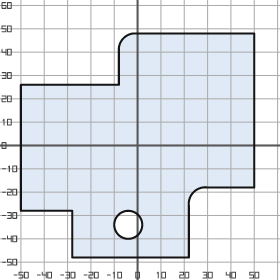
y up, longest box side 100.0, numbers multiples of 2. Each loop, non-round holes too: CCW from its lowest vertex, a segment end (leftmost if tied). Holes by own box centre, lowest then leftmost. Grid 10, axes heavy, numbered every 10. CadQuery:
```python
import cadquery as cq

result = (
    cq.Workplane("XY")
    .moveTo(-28.0, -48.0)
    .lineTo(22.0, -48.0)
    .lineTo(22.0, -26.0)
    .threePointArc((24.0, -20.0), (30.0, -18.0))
    .lineTo(50.0, -18.0)
    .lineTo(50.0, 48.0)
    .lineTo(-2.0, 48.0)
    .threePointArc((-6.0, 46.0), (-8.0, 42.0))
    .lineTo(-8.0, 26.0)
    .lineTo(-50.0, 26.0)
    .lineTo(-50.0, -28.0)
    .lineTo(-28.0, -28.0)
    .close()
    .moveTo(-4.0, -34.0)
    .circle(6.0)
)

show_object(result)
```